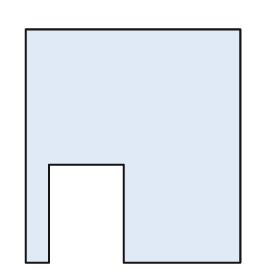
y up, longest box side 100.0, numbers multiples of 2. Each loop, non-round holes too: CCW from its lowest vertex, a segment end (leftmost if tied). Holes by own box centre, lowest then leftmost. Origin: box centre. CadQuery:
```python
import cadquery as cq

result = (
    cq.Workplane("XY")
    .moveTo(-46.0, -50.0)
    .lineTo(-36.0, -50.0)
    .lineTo(-36.0, -8.0)
    .lineTo(-4.0, -8.0)
    .lineTo(-4.0, -50.0)
    .lineTo(46.0, -50.0)
    .lineTo(46.0, 50.0)
    .lineTo(-46.0, 50.0)
    .close()
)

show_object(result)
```